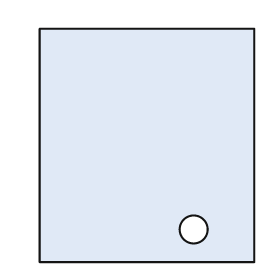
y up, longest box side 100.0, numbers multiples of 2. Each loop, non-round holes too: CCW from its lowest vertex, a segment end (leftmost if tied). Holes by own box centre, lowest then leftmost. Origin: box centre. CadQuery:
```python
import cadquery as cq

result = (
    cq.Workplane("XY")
    .moveTo(-46.0, -50.0)
    .lineTo(46.0, -50.0)
    .lineTo(46.0, 50.0)
    .lineTo(-46.0, 50.0)
    .close()
    .moveTo(20.0, -36.0)
    .circle(6.0)
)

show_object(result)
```